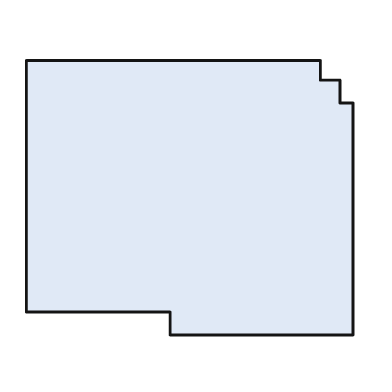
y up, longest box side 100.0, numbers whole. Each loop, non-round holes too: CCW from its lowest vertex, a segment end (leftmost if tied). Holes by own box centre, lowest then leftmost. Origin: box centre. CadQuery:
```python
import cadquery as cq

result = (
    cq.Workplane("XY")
    .moveTo(-6.0, -42.0)
    .lineTo(50.0, -42.0)
    .lineTo(50.0, 29.0)
    .lineTo(46.0, 29.0)
    .lineTo(46.0, 36.0)
    .lineTo(40.0, 36.0)
    .lineTo(40.0, 42.0)
    .lineTo(-50.0, 42.0)
    .lineTo(-50.0, -35.0)
    .lineTo(-6.0, -35.0)
    .close()
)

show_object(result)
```